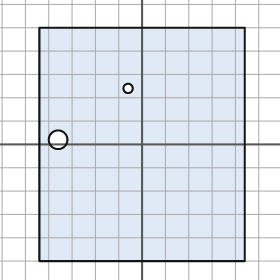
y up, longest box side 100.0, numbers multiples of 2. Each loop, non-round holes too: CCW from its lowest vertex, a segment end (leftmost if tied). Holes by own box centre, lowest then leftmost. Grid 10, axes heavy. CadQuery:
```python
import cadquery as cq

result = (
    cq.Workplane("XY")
    .moveTo(-44.0, -50.0)
    .lineTo(44.0, -50.0)
    .lineTo(44.0, 50.0)
    .lineTo(-44.0, 50.0)
    .close()
    .moveTo(-36.0, 2.0)
    .circle(4.0)
    .moveTo(-6.0, 24.0)
    .circle(2.0)
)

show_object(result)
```